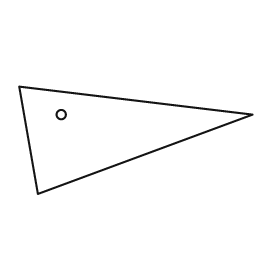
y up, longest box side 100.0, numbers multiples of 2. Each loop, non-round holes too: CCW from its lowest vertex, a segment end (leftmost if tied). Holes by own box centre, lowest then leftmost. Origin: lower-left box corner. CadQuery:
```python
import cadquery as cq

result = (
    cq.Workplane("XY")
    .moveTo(8.0, 0.0)
    .lineTo(100.0, 34.0)
    .lineTo(0.0, 46.0)
    .close()
    .moveTo(18.0, 34.0)
    .circle(2.0)
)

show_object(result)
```